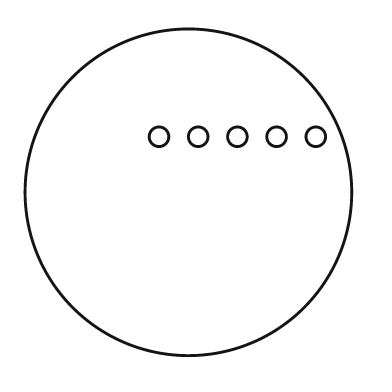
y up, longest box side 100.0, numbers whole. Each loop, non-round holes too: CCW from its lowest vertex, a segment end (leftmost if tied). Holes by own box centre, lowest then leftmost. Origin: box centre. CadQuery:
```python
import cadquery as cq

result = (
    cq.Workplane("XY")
    .moveTo(0.0, 0.0)
    .circle(50.0)
    .moveTo(-9.0, 17.0)
    .circle(3.0)
    .moveTo(3.0, 17.0)
    .circle(3.0)
    .moveTo(15.0, 17.0)
    .circle(3.0)
    .moveTo(27.0, 17.0)
    .circle(3.0)
    .moveTo(39.0, 17.0)
    .circle(3.0)
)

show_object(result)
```